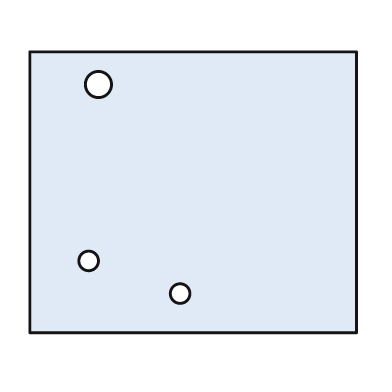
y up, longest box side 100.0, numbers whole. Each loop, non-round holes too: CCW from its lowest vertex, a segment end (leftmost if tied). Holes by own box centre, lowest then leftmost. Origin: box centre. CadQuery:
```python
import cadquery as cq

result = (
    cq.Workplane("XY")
    .moveTo(-50.0, -43.0)
    .lineTo(50.0, -43.0)
    .lineTo(50.0, 43.0)
    .lineTo(-50.0, 43.0)
    .close()
    .moveTo(-4.0, -31.0)
    .circle(3.0)
    .moveTo(-32.0, -21.0)
    .circle(3.0)
    .moveTo(-29.0, 33.0)
    .circle(4.0)
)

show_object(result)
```